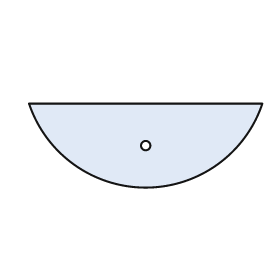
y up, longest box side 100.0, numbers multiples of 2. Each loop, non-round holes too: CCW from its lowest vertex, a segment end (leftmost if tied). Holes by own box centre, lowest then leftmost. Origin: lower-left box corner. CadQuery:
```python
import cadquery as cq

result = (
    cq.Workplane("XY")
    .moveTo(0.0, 36.0)
    .threePointArc((50.0, 0.0), (100.0, 36.0))
    .close()
    .moveTo(50.0, 18.0)
    .circle(2.0)
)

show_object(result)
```